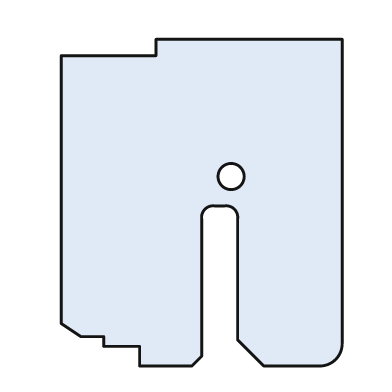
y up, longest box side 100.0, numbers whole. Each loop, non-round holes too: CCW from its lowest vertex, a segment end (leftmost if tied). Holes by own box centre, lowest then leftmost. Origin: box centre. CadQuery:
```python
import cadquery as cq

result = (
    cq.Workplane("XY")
    .moveTo(-19.0, -50.0)
    .lineTo(-3.0, -50.0)
    .lineTo(0.0, -47.0)
    .lineTo(0.0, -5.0)
    .threePointArc((1.0, -2.0), (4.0, -1.0))
    .lineTo(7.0, -1.0)
    .threePointArc((10.0, -2.0), (11.0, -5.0))
    .lineTo(11.0, -42.0)
    .lineTo(19.0, -50.0)
    .lineTo(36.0, -50.0)
    .threePointArc((41.0, -48.0), (43.0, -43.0))
    .lineTo(43.0, 50.0)
    .lineTo(-14.0, 50.0)
    .lineTo(-14.0, 45.0)
    .lineTo(-43.0, 45.0)
    .lineTo(-43.0, -37.0)
    .lineTo(-37.0, -41.0)
    .lineTo(-30.0, -41.0)
    .lineTo(-30.0, -44.0)
    .lineTo(-19.0, -44.0)
    .close()
    .moveTo(9.0, 8.0)
    .circle(4.0)
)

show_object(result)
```